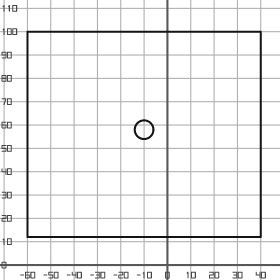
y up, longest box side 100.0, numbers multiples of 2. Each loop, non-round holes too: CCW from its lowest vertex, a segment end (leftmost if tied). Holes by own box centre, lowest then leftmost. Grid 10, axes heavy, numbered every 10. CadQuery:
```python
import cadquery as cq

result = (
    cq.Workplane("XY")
    .moveTo(-60.0, 12.0)
    .lineTo(40.0, 12.0)
    .lineTo(40.0, 100.0)
    .lineTo(-60.0, 100.0)
    .close()
    .moveTo(-10.0, 58.0)
    .circle(4.0)
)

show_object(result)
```